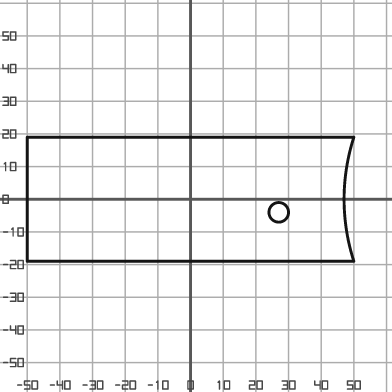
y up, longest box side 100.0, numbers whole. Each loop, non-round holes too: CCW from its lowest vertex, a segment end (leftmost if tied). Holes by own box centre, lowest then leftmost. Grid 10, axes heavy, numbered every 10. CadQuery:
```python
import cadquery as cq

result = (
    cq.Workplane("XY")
    .moveTo(-50.0, -19.0)
    .lineTo(50.0, -19.0)
    .threePointArc((47.0, 0.0), (50.0, 19.0))
    .lineTo(-50.0, 19.0)
    .close()
    .moveTo(27.0, -4.0)
    .circle(3.0)
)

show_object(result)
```